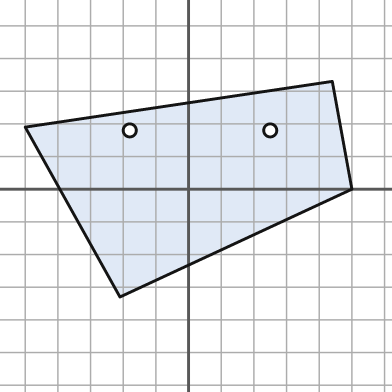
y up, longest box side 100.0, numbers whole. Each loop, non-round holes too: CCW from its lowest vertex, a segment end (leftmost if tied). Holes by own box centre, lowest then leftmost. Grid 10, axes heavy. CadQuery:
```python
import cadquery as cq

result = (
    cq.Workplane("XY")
    .moveTo(-21.0, -33.0)
    .lineTo(50.0, 0.0)
    .lineTo(44.0, 33.0)
    .lineTo(-50.0, 19.0)
    .close()
    .moveTo(-18.0, 18.0)
    .circle(2.0)
    .moveTo(25.0, 18.0)
    .circle(2.0)
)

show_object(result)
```